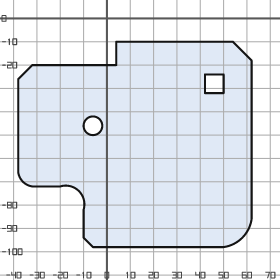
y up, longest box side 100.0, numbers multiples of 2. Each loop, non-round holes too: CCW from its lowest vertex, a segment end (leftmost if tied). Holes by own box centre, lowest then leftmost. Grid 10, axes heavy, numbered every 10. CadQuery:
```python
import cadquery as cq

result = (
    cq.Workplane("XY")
    .moveTo(-6.0, -98.0)
    .lineTo(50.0, -98.0)
    .threePointArc((58.0, -94.0), (62.0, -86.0))
    .lineTo(62.0, -18.0)
    .lineTo(54.0, -10.0)
    .lineTo(4.0, -10.0)
    .lineTo(4.0, -20.0)
    .lineTo(-32.0, -20.0)
    .lineTo(-38.0, -26.0)
    .lineTo(-38.0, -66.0)
    .threePointArc((-36.0, -70.0), (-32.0, -72.0))
    .lineTo(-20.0, -72.0)
    .threePointArc((-12.0, -74.0), (-10.0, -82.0))
    .lineTo(-10.0, -94.0)
    .close()
    .moveTo(-6.0, -46.0)
    .circle(4.0)
    .moveTo(42.0, -32.0)
    .lineTo(50.0, -32.0)
    .lineTo(50.0, -24.0)
    .lineTo(42.0, -24.0)
    .close()
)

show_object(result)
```